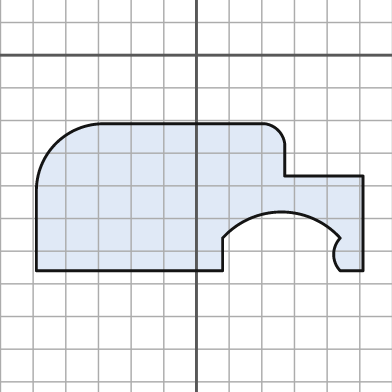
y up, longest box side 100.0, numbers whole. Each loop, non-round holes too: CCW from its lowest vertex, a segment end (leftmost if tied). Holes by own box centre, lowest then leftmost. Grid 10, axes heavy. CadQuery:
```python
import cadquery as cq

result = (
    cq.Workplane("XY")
    .moveTo(-49.0, -66.0)
    .lineTo(8.0, -66.0)
    .lineTo(8.0, -56.0)
    .threePointArc((26.0, -48.0), (44.0, -56.0))
    .threePointArc((42.0, -61.0), (44.0, -66.0))
    .lineTo(51.0, -66.0)
    .lineTo(51.0, -37.0)
    .lineTo(27.0, -37.0)
    .lineTo(27.0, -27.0)
    .threePointArc((25.0, -23.0), (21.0, -21.0))
    .lineTo(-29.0, -21.0)
    .threePointArc((-43.0, -27.0), (-49.0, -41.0))
    .close()
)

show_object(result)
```